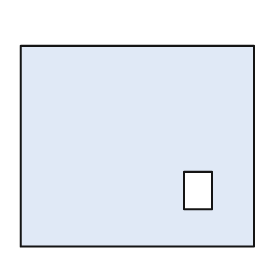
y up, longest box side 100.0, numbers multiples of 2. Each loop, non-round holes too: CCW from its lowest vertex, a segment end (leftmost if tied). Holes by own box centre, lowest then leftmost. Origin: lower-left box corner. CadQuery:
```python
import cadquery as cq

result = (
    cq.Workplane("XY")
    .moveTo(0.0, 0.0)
    .lineTo(100.0, 0.0)
    .lineTo(100.0, 86.0)
    .lineTo(0.0, 86.0)
    .close()
    .moveTo(70.0, 16.0)
    .lineTo(82.0, 16.0)
    .lineTo(82.0, 32.0)
    .lineTo(70.0, 32.0)
    .close()
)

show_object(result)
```